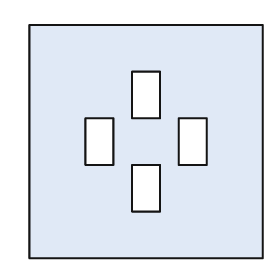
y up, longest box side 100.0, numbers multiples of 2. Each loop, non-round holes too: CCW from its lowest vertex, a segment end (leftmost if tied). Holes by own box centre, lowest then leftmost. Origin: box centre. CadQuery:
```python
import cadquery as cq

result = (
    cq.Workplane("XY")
    .moveTo(-50.0, -50.0)
    .lineTo(50.0, -50.0)
    .lineTo(50.0, 50.0)
    .lineTo(-50.0, 50.0)
    .close()
    .moveTo(-6.0, -30.0)
    .lineTo(6.0, -30.0)
    .lineTo(6.0, -10.0)
    .lineTo(-6.0, -10.0)
    .close()
    .moveTo(-26.0, -10.0)
    .lineTo(-14.0, -10.0)
    .lineTo(-14.0, 10.0)
    .lineTo(-26.0, 10.0)
    .close()
    .moveTo(14.0, -10.0)
    .lineTo(26.0, -10.0)
    .lineTo(26.0, 10.0)
    .lineTo(14.0, 10.0)
    .close()
    .moveTo(-6.0, 10.0)
    .lineTo(6.0, 10.0)
    .lineTo(6.0, 30.0)
    .lineTo(-6.0, 30.0)
    .close()
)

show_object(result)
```